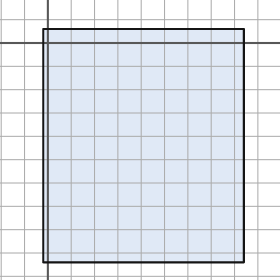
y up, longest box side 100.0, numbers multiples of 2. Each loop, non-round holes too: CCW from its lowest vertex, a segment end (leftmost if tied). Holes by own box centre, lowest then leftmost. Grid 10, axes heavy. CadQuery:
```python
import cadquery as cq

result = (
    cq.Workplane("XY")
    .moveTo(-2.0, -94.0)
    .lineTo(84.0, -94.0)
    .lineTo(84.0, 6.0)
    .lineTo(-2.0, 6.0)
    .close()
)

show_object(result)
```